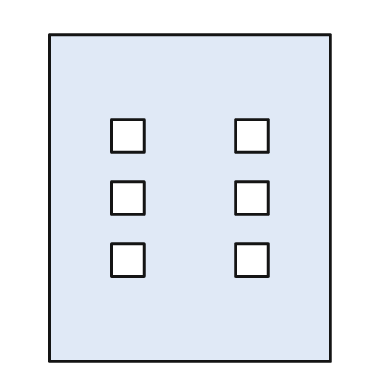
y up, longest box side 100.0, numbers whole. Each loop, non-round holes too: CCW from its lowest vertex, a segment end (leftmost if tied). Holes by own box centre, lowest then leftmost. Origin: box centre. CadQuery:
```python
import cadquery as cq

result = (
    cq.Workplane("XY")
    .moveTo(-43.0, -50.0)
    .lineTo(43.0, -50.0)
    .lineTo(43.0, 50.0)
    .lineTo(-43.0, 50.0)
    .close()
    .moveTo(-24.0, -24.0)
    .lineTo(-14.0, -24.0)
    .lineTo(-14.0, -14.0)
    .lineTo(-24.0, -14.0)
    .close()
    .moveTo(14.0, -24.0)
    .lineTo(24.0, -24.0)
    .lineTo(24.0, -14.0)
    .lineTo(14.0, -14.0)
    .close()
    .moveTo(-24.0, -5.0)
    .lineTo(-14.0, -5.0)
    .lineTo(-14.0, 5.0)
    .lineTo(-24.0, 5.0)
    .close()
    .moveTo(14.0, -5.0)
    .lineTo(24.0, -5.0)
    .lineTo(24.0, 5.0)
    .lineTo(14.0, 5.0)
    .close()
    .moveTo(-24.0, 14.0)
    .lineTo(-14.0, 14.0)
    .lineTo(-14.0, 24.0)
    .lineTo(-24.0, 24.0)
    .close()
    .moveTo(14.0, 14.0)
    .lineTo(24.0, 14.0)
    .lineTo(24.0, 24.0)
    .lineTo(14.0, 24.0)
    .close()
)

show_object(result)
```